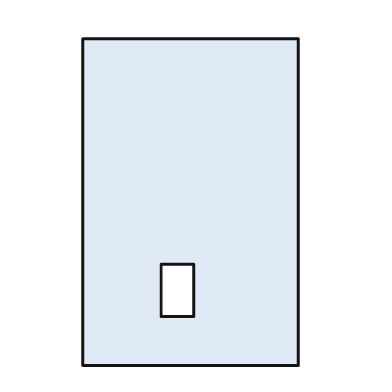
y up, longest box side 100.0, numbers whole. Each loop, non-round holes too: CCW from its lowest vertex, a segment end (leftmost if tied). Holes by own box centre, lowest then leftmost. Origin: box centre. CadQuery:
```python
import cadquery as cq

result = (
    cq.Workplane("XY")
    .moveTo(-33.0, -50.0)
    .lineTo(33.0, -50.0)
    .lineTo(33.0, 50.0)
    .lineTo(-33.0, 50.0)
    .close()
    .moveTo(-9.0, -35.0)
    .lineTo(1.0, -35.0)
    .lineTo(1.0, -19.0)
    .lineTo(-9.0, -19.0)
    .close()
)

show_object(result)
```